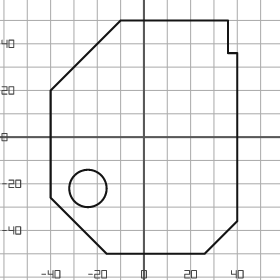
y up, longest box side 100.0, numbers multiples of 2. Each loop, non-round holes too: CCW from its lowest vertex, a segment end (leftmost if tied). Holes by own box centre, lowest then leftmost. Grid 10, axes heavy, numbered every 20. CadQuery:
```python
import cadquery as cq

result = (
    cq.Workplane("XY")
    .moveTo(-16.0, -50.0)
    .lineTo(26.0, -50.0)
    .lineTo(40.0, -36.0)
    .lineTo(40.0, 36.0)
    .lineTo(36.0, 36.0)
    .lineTo(36.0, 50.0)
    .lineTo(-10.0, 50.0)
    .lineTo(-40.0, 20.0)
    .lineTo(-40.0, -26.0)
    .close()
    .moveTo(-24.0, -22.0)
    .circle(8.0)
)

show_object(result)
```